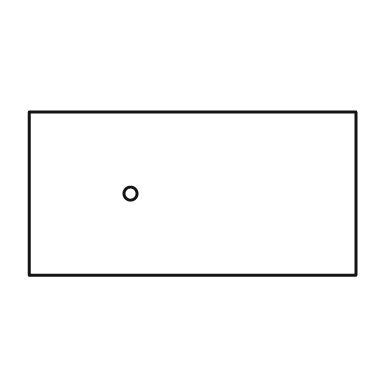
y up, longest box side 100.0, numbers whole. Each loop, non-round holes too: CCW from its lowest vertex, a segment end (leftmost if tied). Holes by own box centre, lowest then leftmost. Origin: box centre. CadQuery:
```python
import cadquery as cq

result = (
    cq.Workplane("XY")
    .moveTo(-50.0, -25.0)
    .lineTo(50.0, -25.0)
    .lineTo(50.0, 25.0)
    .lineTo(-50.0, 25.0)
    .close()
    .moveTo(-19.0, 0.0)
    .circle(2.0)
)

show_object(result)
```